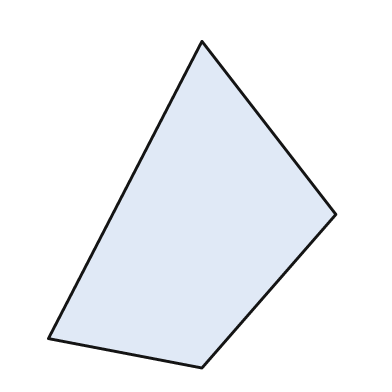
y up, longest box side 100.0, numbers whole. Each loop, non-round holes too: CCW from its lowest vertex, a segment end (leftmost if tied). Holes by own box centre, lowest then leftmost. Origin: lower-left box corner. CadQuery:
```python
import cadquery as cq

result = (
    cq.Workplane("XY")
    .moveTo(47.0, 0.0)
    .lineTo(88.0, 47.0)
    .lineTo(47.0, 100.0)
    .lineTo(0.0, 9.0)
    .close()
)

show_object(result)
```